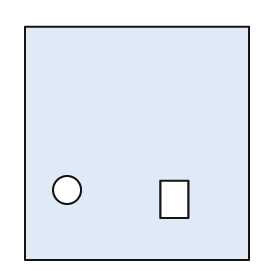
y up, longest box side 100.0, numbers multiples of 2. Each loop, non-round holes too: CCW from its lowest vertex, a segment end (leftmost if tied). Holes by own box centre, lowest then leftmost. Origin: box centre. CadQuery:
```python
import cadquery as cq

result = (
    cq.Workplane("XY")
    .moveTo(-48.0, -50.0)
    .lineTo(48.0, -50.0)
    .lineTo(48.0, 50.0)
    .lineTo(-48.0, 50.0)
    .close()
    .moveTo(10.0, -32.0)
    .lineTo(22.0, -32.0)
    .lineTo(22.0, -16.0)
    .lineTo(10.0, -16.0)
    .close()
    .moveTo(-30.0, -20.0)
    .circle(6.0)
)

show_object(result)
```